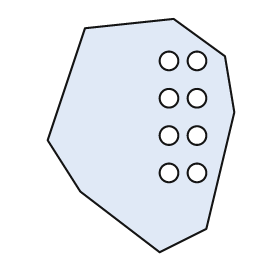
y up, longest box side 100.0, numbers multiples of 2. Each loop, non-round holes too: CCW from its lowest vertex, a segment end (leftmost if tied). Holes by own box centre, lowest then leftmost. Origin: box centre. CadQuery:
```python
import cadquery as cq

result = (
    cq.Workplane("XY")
    .moveTo(8.0, -50.0)
    .lineTo(28.0, -40.0)
    .lineTo(40.0, 10.0)
    .lineTo(36.0, 34.0)
    .lineTo(14.0, 50.0)
    .lineTo(-24.0, 46.0)
    .lineTo(-40.0, -2.0)
    .lineTo(-26.0, -24.0)
    .close()
    .moveTo(12.0, -16.0)
    .circle(4.0)
    .moveTo(24.0, -16.0)
    .circle(4.0)
    .moveTo(12.0, 0.0)
    .circle(4.0)
    .moveTo(24.0, 0.0)
    .circle(4.0)
    .moveTo(12.0, 16.0)
    .circle(4.0)
    .moveTo(24.0, 16.0)
    .circle(4.0)
    .moveTo(12.0, 32.0)
    .circle(4.0)
    .moveTo(24.0, 32.0)
    .circle(4.0)
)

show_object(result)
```